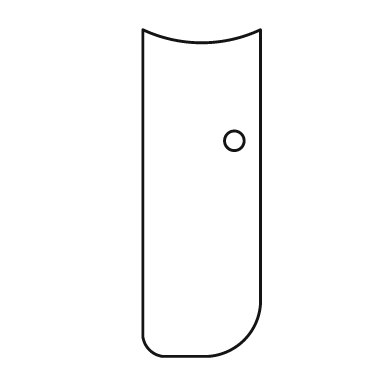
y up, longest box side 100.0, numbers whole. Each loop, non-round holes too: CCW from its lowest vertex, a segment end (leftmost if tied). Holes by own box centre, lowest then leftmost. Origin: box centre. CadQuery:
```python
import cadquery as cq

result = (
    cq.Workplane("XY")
    .moveTo(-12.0, -50.0)
    .lineTo(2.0, -50.0)
    .threePointArc((13.0, -45.0), (18.0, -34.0))
    .lineTo(18.0, 50.0)
    .threePointArc((0.0, 46.0), (-18.0, 50.0))
    .lineTo(-18.0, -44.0)
    .threePointArc((-16.0, -48.0), (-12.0, -50.0))
    .close()
    .moveTo(10.0, 16.0)
    .circle(3.0)
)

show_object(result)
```